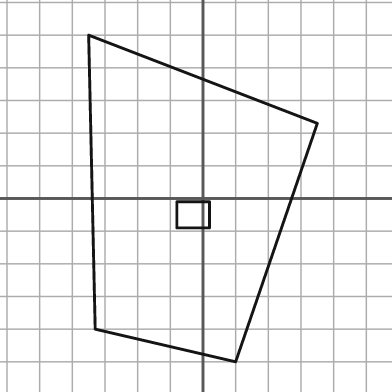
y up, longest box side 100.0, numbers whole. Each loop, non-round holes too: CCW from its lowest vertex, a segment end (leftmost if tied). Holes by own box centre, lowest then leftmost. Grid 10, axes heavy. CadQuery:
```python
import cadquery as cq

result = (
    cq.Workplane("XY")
    .moveTo(10.0, -50.0)
    .lineTo(35.0, 23.0)
    .lineTo(-35.0, 50.0)
    .lineTo(-33.0, -40.0)
    .close()
    .moveTo(-8.0, -9.0)
    .lineTo(2.0, -9.0)
    .lineTo(2.0, -1.0)
    .lineTo(-8.0, -1.0)
    .close()
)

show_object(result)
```